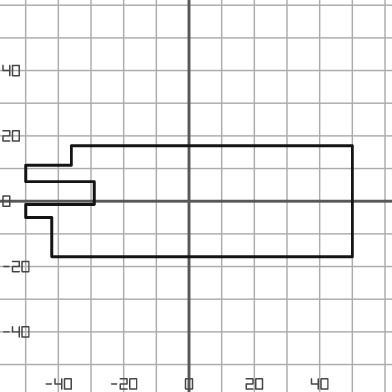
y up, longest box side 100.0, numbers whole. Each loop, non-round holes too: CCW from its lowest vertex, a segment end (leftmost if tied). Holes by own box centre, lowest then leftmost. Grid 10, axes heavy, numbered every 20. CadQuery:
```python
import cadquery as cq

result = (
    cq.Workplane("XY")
    .moveTo(-42.0, -17.0)
    .lineTo(50.0, -17.0)
    .lineTo(50.0, 17.0)
    .lineTo(-36.0, 17.0)
    .lineTo(-36.0, 11.0)
    .lineTo(-50.0, 11.0)
    .lineTo(-50.0, 6.0)
    .lineTo(-29.0, 6.0)
    .lineTo(-29.0, -1.0)
    .lineTo(-50.0, -1.0)
    .lineTo(-50.0, -5.0)
    .lineTo(-42.0, -5.0)
    .close()
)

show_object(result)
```